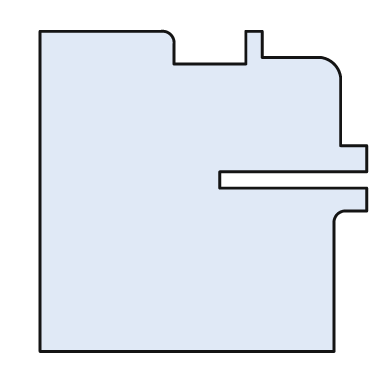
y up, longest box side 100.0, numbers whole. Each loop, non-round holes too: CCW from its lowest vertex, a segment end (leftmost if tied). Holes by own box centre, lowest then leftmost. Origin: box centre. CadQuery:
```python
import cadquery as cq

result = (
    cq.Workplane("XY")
    .moveTo(-50.0, -49.0)
    .lineTo(40.0, -49.0)
    .lineTo(40.0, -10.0)
    .threePointArc((41.0, -7.0), (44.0, -6.0))
    .lineTo(50.0, -6.0)
    .lineTo(50.0, 1.0)
    .lineTo(5.0, 1.0)
    .lineTo(5.0, 6.0)
    .lineTo(50.0, 6.0)
    .lineTo(50.0, 14.0)
    .lineTo(42.0, 14.0)
    .lineTo(42.0, 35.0)
    .threePointArc((40.0, 39.0), (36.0, 41.0))
    .lineTo(18.0, 41.0)
    .lineTo(18.0, 49.0)
    .lineTo(13.0, 49.0)
    .lineTo(13.0, 39.0)
    .lineTo(-9.0, 39.0)
    .lineTo(-9.0, 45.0)
    .threePointArc((-10.0, 48.0), (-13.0, 49.0))
    .lineTo(-50.0, 49.0)
    .close()
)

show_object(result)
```